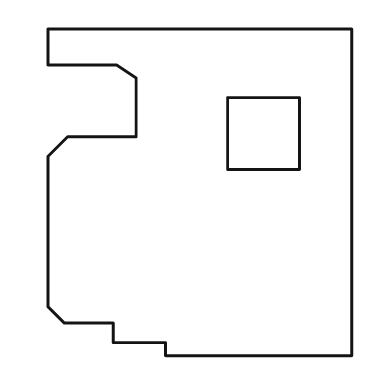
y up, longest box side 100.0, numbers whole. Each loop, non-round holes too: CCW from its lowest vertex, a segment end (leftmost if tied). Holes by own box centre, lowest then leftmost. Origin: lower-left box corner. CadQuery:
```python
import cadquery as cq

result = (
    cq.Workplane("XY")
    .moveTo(36.0, 0.0)
    .lineTo(93.0, 0.0)
    .lineTo(93.0, 100.0)
    .lineTo(0.0, 100.0)
    .lineTo(0.0, 89.0)
    .lineTo(21.0, 89.0)
    .lineTo(27.0, 85.0)
    .lineTo(27.0, 67.0)
    .lineTo(6.0, 67.0)
    .lineTo(0.0, 61.0)
    .lineTo(0.0, 15.0)
    .lineTo(5.0, 10.0)
    .lineTo(20.0, 10.0)
    .lineTo(20.0, 4.0)
    .lineTo(36.0, 4.0)
    .close()
    .moveTo(55.0, 57.0)
    .lineTo(77.0, 57.0)
    .lineTo(77.0, 79.0)
    .lineTo(55.0, 79.0)
    .close()
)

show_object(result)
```